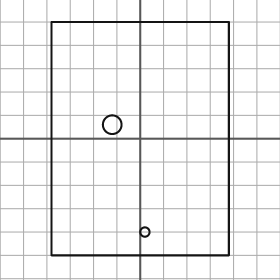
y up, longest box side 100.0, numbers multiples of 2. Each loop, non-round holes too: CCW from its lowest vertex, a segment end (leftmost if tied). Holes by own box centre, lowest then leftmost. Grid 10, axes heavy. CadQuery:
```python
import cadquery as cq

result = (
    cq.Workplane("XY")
    .moveTo(-38.0, -50.0)
    .lineTo(38.0, -50.0)
    .lineTo(38.0, 50.0)
    .lineTo(-38.0, 50.0)
    .close()
    .moveTo(2.0, -40.0)
    .circle(2.0)
    .moveTo(-12.0, 6.0)
    .circle(4.0)
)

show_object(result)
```